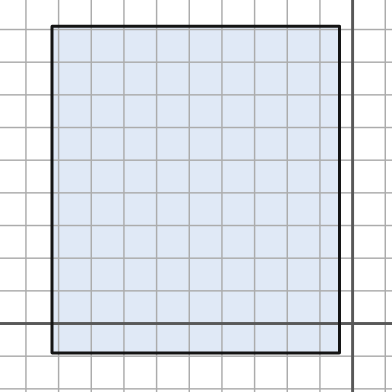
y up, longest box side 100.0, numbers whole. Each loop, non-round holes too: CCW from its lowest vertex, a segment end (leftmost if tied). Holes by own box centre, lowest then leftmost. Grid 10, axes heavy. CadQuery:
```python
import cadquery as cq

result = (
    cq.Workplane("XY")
    .moveTo(-92.0, -9.0)
    .lineTo(-4.0, -9.0)
    .lineTo(-4.0, 91.0)
    .lineTo(-92.0, 91.0)
    .close()
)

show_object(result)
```